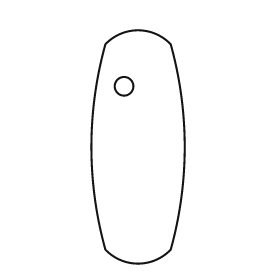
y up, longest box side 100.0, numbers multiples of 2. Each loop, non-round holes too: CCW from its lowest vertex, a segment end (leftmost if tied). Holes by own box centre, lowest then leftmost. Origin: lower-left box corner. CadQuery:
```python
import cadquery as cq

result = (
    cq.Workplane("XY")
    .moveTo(6.0, 6.0)
    .threePointArc((20.0, 0.0), (34.0, 6.0))
    .threePointArc((40.0, 50.0), (34.0, 94.0))
    .threePointArc((20.0, 100.0), (6.0, 94.0))
    .threePointArc((0.0, 50.0), (6.0, 6.0))
    .close()
    .moveTo(14.0, 76.0)
    .circle(4.0)
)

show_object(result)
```